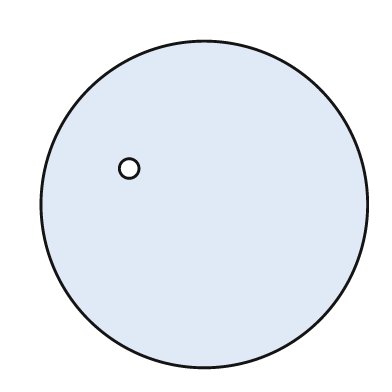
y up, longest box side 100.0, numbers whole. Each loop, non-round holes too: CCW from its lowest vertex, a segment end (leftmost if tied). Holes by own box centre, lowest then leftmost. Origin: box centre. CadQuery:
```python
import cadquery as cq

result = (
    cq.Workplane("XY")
    .moveTo(0.0, 0.0)
    .circle(50.0)
    .moveTo(-23.0, 11.0)
    .circle(3.0)
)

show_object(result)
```